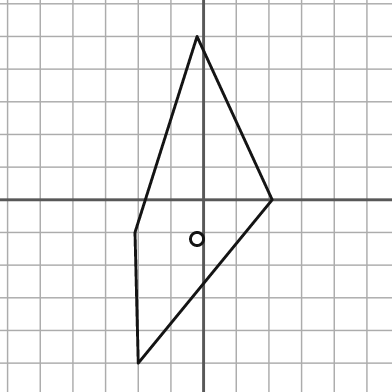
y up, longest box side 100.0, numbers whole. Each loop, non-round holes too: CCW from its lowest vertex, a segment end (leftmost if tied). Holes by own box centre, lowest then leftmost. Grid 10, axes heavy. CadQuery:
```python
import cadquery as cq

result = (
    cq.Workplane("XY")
    .moveTo(-20.0, -50.0)
    .lineTo(21.0, 0.0)
    .lineTo(-2.0, 50.0)
    .lineTo(-21.0, -10.0)
    .close()
    .moveTo(-2.0, -12.0)
    .circle(2.0)
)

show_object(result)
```